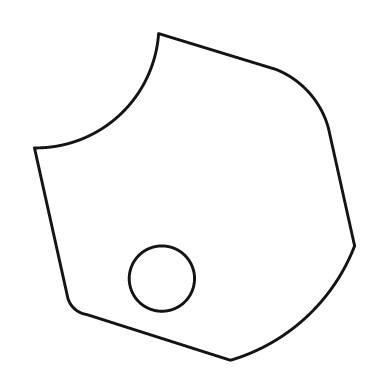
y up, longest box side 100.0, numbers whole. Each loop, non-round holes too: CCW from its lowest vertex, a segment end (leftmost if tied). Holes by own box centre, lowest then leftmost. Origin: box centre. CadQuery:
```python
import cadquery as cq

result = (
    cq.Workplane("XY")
    .moveTo(11.0, -50.0)
    .threePointArc((34.0, -37.0), (49.0, -15.0))
    .lineTo(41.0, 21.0)
    .threePointArc((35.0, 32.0), (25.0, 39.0))
    .lineTo(-11.0, 50.0)
    .threePointArc((-23.0, 25.0), (-49.0, 15.0))
    .lineTo(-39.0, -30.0)
    .threePointArc((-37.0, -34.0), (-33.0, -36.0))
    .close()
    .moveTo(-10.0, -25.0)
    .circle(10.0)
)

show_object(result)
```